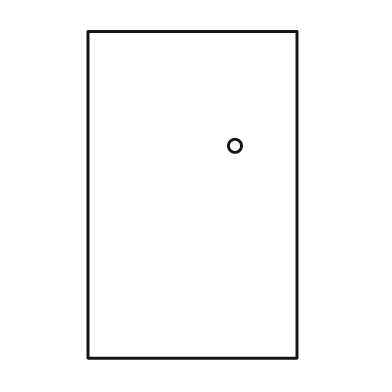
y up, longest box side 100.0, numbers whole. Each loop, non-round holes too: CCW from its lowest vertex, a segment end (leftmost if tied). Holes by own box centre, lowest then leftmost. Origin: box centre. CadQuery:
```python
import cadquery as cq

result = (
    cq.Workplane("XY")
    .moveTo(-32.0, -50.0)
    .lineTo(32.0, -50.0)
    .lineTo(32.0, 50.0)
    .lineTo(-32.0, 50.0)
    .close()
    .moveTo(13.0, 15.0)
    .circle(2.0)
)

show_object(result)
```